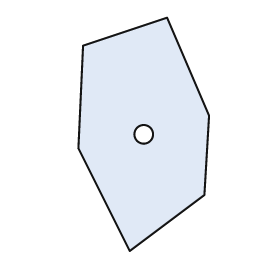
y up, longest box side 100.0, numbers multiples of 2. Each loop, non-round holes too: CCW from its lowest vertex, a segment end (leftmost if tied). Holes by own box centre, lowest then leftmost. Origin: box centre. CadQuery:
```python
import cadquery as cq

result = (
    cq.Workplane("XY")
    .moveTo(-6.0, -50.0)
    .lineTo(26.0, -26.0)
    .lineTo(28.0, 8.0)
    .lineTo(10.0, 50.0)
    .lineTo(-26.0, 38.0)
    .lineTo(-28.0, -6.0)
    .close()
    .moveTo(0.0, 0.0)
    .circle(4.0)
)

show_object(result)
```